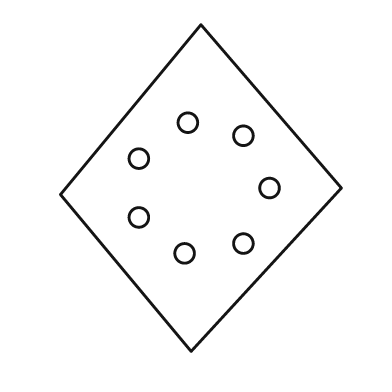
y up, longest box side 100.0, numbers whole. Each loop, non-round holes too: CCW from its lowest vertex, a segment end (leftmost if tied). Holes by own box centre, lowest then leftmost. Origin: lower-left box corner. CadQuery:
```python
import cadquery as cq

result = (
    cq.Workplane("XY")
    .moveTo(40.0, 0.0)
    .lineTo(86.0, 50.0)
    .lineTo(43.0, 100.0)
    .lineTo(0.0, 48.0)
    .close()
    .moveTo(38.0, 30.0)
    .circle(3.0)
    .moveTo(56.0, 33.0)
    .circle(3.0)
    .moveTo(24.0, 41.0)
    .circle(3.0)
    .moveTo(64.0, 50.0)
    .circle(3.0)
    .moveTo(24.0, 59.0)
    .circle(3.0)
    .moveTo(56.0, 66.0)
    .circle(3.0)
    .moveTo(39.0, 70.0)
    .circle(3.0)
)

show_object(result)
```